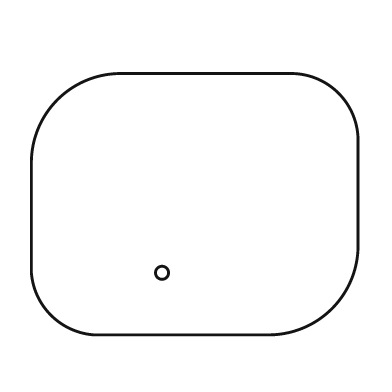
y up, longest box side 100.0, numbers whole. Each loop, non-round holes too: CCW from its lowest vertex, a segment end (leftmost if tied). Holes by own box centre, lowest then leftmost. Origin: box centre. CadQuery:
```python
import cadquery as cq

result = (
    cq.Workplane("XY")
    .moveTo(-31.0, -40.0)
    .lineTo(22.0, -40.0)
    .threePointArc((42.0, -32.0), (50.0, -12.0))
    .lineTo(50.0, 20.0)
    .threePointArc((44.0, 34.0), (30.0, 40.0))
    .lineTo(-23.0, 40.0)
    .threePointArc((-42.0, 32.0), (-50.0, 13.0))
    .lineTo(-50.0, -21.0)
    .threePointArc((-44.0, -34.0), (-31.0, -40.0))
    .close()
    .moveTo(-10.0, -21.0)
    .circle(2.0)
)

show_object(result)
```